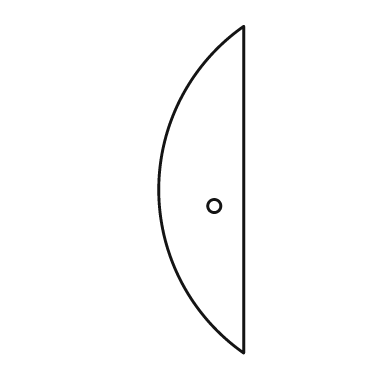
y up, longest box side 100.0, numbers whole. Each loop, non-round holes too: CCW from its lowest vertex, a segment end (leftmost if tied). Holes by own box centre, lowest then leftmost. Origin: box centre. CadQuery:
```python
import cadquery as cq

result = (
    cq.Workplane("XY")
    .moveTo(13.0, -50.0)
    .lineTo(13.0, 50.0)
    .threePointArc((-13.0, 0.0), (13.0, -50.0))
    .close()
    .moveTo(4.0, -5.0)
    .circle(2.0)
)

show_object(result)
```